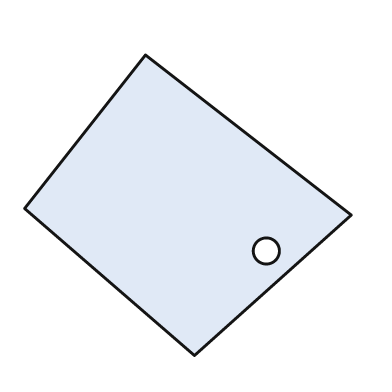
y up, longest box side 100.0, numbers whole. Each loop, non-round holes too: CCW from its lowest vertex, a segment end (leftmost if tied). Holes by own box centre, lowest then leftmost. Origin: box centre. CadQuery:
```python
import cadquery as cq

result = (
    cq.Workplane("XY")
    .moveTo(2.0, -46.0)
    .lineTo(50.0, -3.0)
    .lineTo(-13.0, 46.0)
    .lineTo(-50.0, -1.0)
    .close()
    .moveTo(24.0, -14.0)
    .circle(4.0)
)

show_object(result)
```